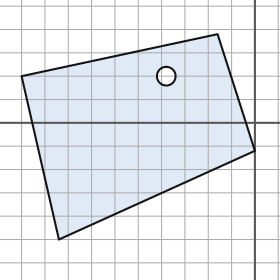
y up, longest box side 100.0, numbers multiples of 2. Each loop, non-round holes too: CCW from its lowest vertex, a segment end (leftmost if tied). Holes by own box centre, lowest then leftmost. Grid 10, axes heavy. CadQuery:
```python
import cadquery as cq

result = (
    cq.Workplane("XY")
    .moveTo(-84.0, -50.0)
    .lineTo(0.0, -12.0)
    .lineTo(-16.0, 38.0)
    .lineTo(-100.0, 20.0)
    .close()
    .moveTo(-38.0, 20.0)
    .circle(4.0)
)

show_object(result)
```